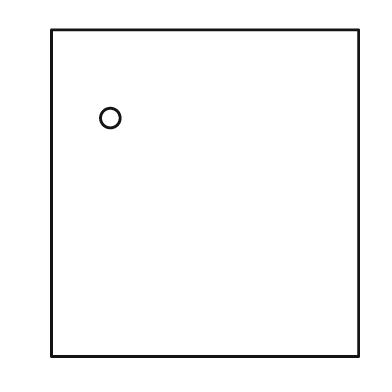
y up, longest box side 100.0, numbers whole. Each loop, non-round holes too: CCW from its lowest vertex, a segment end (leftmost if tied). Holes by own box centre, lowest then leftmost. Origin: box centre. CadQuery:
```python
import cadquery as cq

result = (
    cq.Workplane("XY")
    .moveTo(-47.0, -50.0)
    .lineTo(47.0, -50.0)
    .lineTo(47.0, 50.0)
    .lineTo(-47.0, 50.0)
    .close()
    .moveTo(-29.0, 23.0)
    .circle(3.0)
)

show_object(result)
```